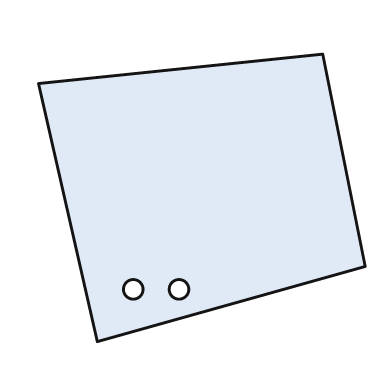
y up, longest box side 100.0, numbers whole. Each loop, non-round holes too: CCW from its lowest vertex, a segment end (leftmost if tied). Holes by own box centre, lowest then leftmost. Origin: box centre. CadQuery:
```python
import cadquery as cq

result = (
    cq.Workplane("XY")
    .moveTo(-32.0, -44.0)
    .lineTo(50.0, -21.0)
    .lineTo(37.0, 44.0)
    .lineTo(-50.0, 35.0)
    .close()
    .moveTo(-21.0, -28.0)
    .circle(3.0)
    .moveTo(-7.0, -28.0)
    .circle(3.0)
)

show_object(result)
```